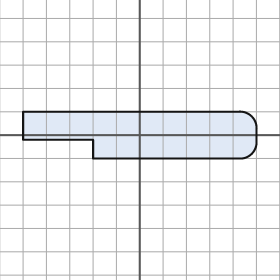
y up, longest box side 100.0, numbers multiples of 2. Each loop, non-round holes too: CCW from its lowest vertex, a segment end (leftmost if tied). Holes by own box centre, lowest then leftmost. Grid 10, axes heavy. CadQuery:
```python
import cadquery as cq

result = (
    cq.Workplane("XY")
    .moveTo(-20.0, -10.0)
    .lineTo(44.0, -10.0)
    .threePointArc((48.0, -8.0), (50.0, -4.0))
    .lineTo(50.0, 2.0)
    .threePointArc((48.0, 8.0), (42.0, 10.0))
    .lineTo(-50.0, 10.0)
    .lineTo(-50.0, -2.0)
    .lineTo(-20.0, -2.0)
    .close()
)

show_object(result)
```